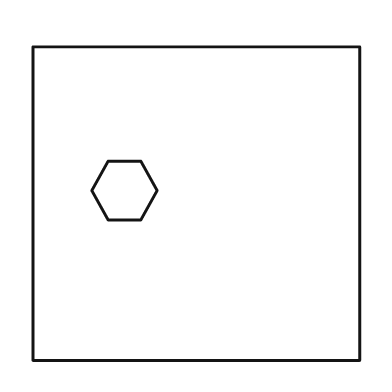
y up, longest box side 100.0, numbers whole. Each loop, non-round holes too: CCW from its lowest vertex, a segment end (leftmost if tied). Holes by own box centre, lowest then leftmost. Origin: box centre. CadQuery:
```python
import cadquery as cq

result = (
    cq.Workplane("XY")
    .moveTo(-50.0, -48.0)
    .lineTo(50.0, -48.0)
    .lineTo(50.0, 48.0)
    .lineTo(-50.0, 48.0)
    .close()
    .moveTo(-27.0, -5.0)
    .lineTo(-17.0, -5.0)
    .lineTo(-12.0, 4.0)
    .lineTo(-17.0, 13.0)
    .lineTo(-27.0, 13.0)
    .lineTo(-32.0, 4.0)
    .close()
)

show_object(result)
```